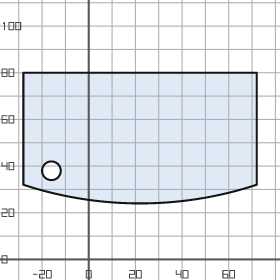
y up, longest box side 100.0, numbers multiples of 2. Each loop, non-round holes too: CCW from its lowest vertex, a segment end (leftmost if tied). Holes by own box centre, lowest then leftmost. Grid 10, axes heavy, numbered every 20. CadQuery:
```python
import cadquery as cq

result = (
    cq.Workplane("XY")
    .moveTo(-28.0, 32.0)
    .threePointArc((22.0, 24.0), (72.0, 32.0))
    .lineTo(72.0, 80.0)
    .lineTo(-28.0, 80.0)
    .close()
    .moveTo(-16.0, 38.0)
    .circle(4.0)
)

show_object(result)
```